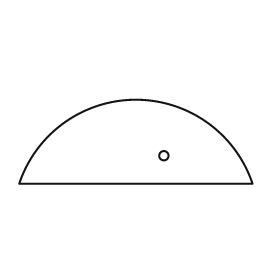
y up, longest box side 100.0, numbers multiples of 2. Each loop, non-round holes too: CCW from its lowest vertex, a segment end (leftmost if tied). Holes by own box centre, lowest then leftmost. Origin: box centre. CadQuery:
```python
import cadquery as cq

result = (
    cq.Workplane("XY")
    .moveTo(-50.0, -18.0)
    .lineTo(50.0, -18.0)
    .threePointArc((0.0, 18.0), (-50.0, -18.0))
    .close()
    .moveTo(12.0, -6.0)
    .circle(2.0)
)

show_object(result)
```